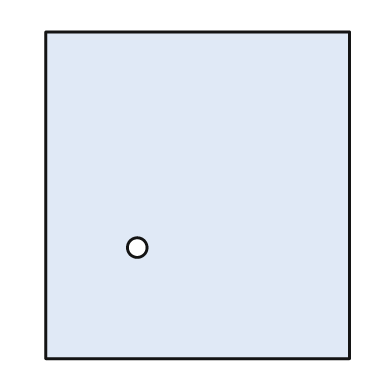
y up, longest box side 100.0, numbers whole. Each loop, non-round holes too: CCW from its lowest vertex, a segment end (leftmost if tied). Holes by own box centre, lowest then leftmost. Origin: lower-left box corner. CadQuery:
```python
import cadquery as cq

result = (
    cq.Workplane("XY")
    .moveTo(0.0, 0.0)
    .lineTo(93.0, 0.0)
    .lineTo(93.0, 100.0)
    .lineTo(0.0, 100.0)
    .close()
    .moveTo(28.0, 34.0)
    .circle(3.0)
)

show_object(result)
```